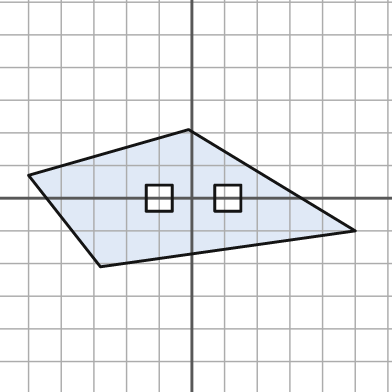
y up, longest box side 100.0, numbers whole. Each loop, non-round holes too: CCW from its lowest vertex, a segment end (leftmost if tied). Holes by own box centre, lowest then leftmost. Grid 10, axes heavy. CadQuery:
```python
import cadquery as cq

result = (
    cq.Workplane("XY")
    .moveTo(-28.0, -21.0)
    .lineTo(50.0, -10.0)
    .lineTo(-1.0, 21.0)
    .lineTo(-50.0, 7.0)
    .close()
    .moveTo(-14.0, -4.0)
    .lineTo(-6.0, -4.0)
    .lineTo(-6.0, 4.0)
    .lineTo(-14.0, 4.0)
    .close()
    .moveTo(7.0, -4.0)
    .lineTo(15.0, -4.0)
    .lineTo(15.0, 4.0)
    .lineTo(7.0, 4.0)
    .close()
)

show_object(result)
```